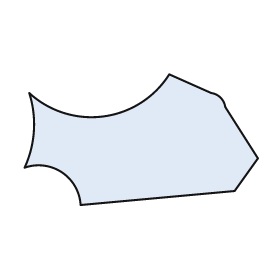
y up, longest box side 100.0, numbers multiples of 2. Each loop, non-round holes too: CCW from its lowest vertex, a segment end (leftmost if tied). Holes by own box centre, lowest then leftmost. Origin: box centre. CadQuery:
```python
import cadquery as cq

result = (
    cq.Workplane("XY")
    .moveTo(-26.0, -28.0)
    .lineTo(40.0, -22.0)
    .lineTo(50.0, -8.0)
    .lineTo(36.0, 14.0)
    .threePointArc((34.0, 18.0), (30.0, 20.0))
    .lineTo(12.0, 28.0)
    .threePointArc((-16.0, 10.0), (-48.0, 20.0))
    .threePointArc((-46.0, 4.0), (-50.0, -12.0))
    .threePointArc((-34.0, -14.0), (-26.0, -28.0))
    .close()
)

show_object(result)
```